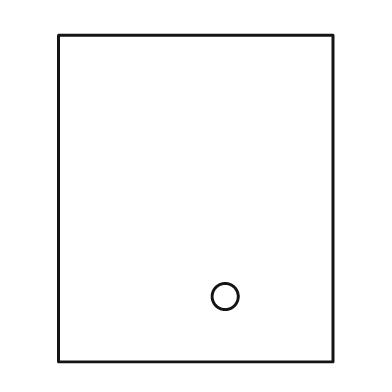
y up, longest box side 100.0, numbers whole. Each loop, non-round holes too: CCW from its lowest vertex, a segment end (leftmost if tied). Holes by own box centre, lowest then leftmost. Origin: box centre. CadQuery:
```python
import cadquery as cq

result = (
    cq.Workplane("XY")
    .moveTo(-42.0, -50.0)
    .lineTo(42.0, -50.0)
    .lineTo(42.0, 50.0)
    .lineTo(-42.0, 50.0)
    .close()
    .moveTo(9.0, -30.0)
    .circle(4.0)
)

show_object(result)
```